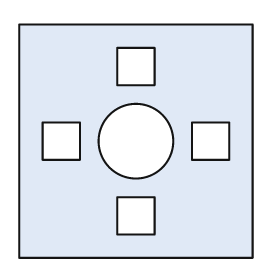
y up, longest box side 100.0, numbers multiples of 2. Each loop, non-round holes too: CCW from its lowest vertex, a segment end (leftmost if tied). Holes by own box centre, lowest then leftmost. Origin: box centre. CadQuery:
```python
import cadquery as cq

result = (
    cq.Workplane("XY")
    .moveTo(-50.0, -50.0)
    .lineTo(50.0, -50.0)
    .lineTo(50.0, 50.0)
    .lineTo(-50.0, 50.0)
    .close()
    .moveTo(-8.0, -40.0)
    .lineTo(8.0, -40.0)
    .lineTo(8.0, -24.0)
    .lineTo(-8.0, -24.0)
    .close()
    .moveTo(-40.0, -8.0)
    .lineTo(-24.0, -8.0)
    .lineTo(-24.0, 8.0)
    .lineTo(-40.0, 8.0)
    .close()
    .moveTo(0.0, 0.0)
    .circle(16.0)
    .moveTo(24.0, -8.0)
    .lineTo(40.0, -8.0)
    .lineTo(40.0, 8.0)
    .lineTo(24.0, 8.0)
    .close()
    .moveTo(-8.0, 24.0)
    .lineTo(8.0, 24.0)
    .lineTo(8.0, 40.0)
    .lineTo(-8.0, 40.0)
    .close()
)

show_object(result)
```